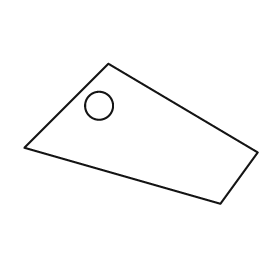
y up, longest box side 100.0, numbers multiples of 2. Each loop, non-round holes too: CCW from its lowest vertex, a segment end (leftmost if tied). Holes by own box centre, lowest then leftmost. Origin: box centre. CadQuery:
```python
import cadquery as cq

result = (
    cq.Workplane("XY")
    .moveTo(34.0, -30.0)
    .lineTo(50.0, -8.0)
    .lineTo(-14.0, 30.0)
    .lineTo(-50.0, -6.0)
    .close()
    .moveTo(-18.0, 12.0)
    .circle(6.0)
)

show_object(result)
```